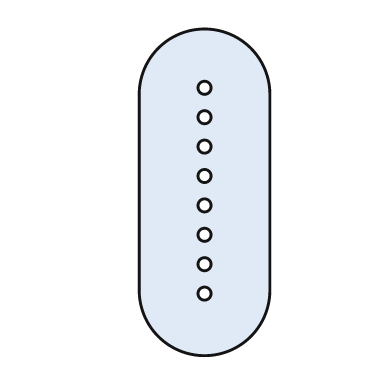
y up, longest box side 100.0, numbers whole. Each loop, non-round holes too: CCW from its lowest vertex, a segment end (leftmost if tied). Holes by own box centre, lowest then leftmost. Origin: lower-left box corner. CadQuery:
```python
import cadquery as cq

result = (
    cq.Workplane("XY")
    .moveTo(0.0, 20.0)
    .threePointArc((20.0, 0.0), (40.0, 20.0))
    .lineTo(40.0, 80.0)
    .threePointArc((20.0, 100.0), (0.0, 80.0))
    .close()
    .moveTo(20.0, 19.0)
    .circle(2.0)
    .moveTo(20.0, 28.0)
    .circle(2.0)
    .moveTo(20.0, 37.0)
    .circle(2.0)
    .moveTo(20.0, 46.0)
    .circle(2.0)
    .moveTo(20.0, 55.0)
    .circle(2.0)
    .moveTo(20.0, 64.0)
    .circle(2.0)
    .moveTo(20.0, 73.0)
    .circle(2.0)
    .moveTo(20.0, 82.0)
    .circle(2.0)
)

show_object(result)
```